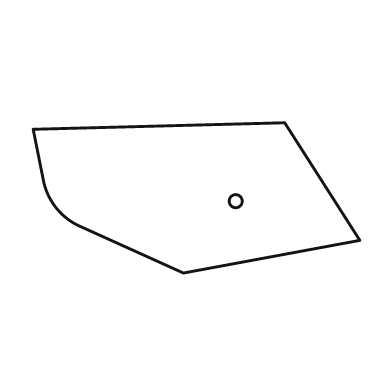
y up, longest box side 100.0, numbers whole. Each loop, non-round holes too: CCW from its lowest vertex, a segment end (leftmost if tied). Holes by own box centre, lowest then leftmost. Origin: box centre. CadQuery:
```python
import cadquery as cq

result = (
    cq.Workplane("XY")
    .moveTo(-4.0, -23.0)
    .lineTo(50.0, -13.0)
    .lineTo(27.0, 23.0)
    .lineTo(-50.0, 21.0)
    .lineTo(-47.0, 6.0)
    .threePointArc((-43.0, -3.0), (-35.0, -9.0))
    .close()
    .moveTo(12.0, -1.0)
    .circle(2.0)
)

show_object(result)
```